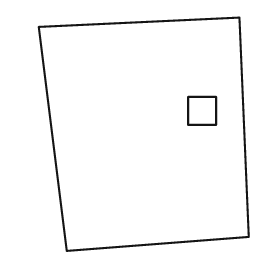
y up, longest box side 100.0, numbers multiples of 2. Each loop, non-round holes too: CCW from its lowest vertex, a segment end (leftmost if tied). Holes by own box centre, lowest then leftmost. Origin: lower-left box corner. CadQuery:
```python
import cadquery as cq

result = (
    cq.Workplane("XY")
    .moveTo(12.0, 0.0)
    .lineTo(90.0, 6.0)
    .lineTo(86.0, 100.0)
    .lineTo(0.0, 96.0)
    .close()
    .moveTo(64.0, 54.0)
    .lineTo(76.0, 54.0)
    .lineTo(76.0, 66.0)
    .lineTo(64.0, 66.0)
    .close()
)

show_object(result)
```